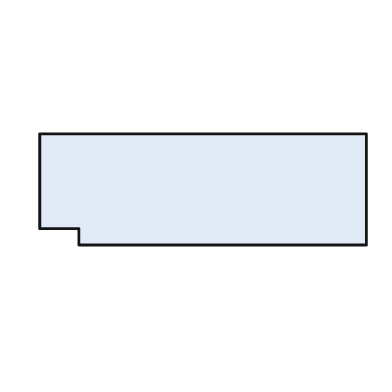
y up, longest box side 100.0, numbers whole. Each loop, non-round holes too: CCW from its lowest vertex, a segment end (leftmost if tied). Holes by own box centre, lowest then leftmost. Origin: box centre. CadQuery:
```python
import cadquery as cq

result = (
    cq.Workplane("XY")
    .moveTo(-38.0, -17.0)
    .lineTo(50.0, -17.0)
    .lineTo(50.0, 17.0)
    .lineTo(-50.0, 17.0)
    .lineTo(-50.0, -12.0)
    .lineTo(-38.0, -12.0)
    .close()
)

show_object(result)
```